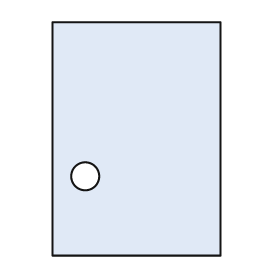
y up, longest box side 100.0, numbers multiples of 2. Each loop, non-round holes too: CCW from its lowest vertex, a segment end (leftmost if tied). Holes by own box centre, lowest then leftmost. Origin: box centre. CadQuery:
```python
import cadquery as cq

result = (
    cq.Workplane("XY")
    .moveTo(-36.0, -50.0)
    .lineTo(36.0, -50.0)
    .lineTo(36.0, 50.0)
    .lineTo(-36.0, 50.0)
    .close()
    .moveTo(-22.0, -16.0)
    .circle(6.0)
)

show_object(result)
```